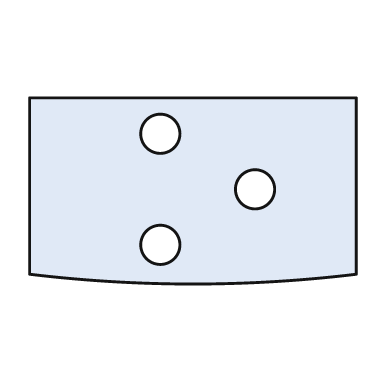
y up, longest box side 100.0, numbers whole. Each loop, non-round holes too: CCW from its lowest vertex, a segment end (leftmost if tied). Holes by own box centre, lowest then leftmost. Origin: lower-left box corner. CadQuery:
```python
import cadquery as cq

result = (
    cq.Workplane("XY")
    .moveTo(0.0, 3.0)
    .threePointArc((50.0, 0.0), (100.0, 3.0))
    .lineTo(100.0, 57.0)
    .lineTo(0.0, 57.0)
    .close()
    .moveTo(40.0, 12.0)
    .circle(6.0)
    .moveTo(69.0, 29.0)
    .circle(6.0)
    .moveTo(40.0, 46.0)
    .circle(6.0)
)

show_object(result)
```